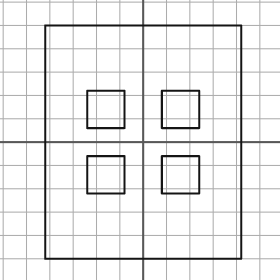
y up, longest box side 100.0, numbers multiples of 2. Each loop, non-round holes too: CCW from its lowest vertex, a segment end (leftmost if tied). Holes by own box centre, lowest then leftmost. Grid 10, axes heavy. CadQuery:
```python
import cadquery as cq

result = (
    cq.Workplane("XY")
    .moveTo(-42.0, -50.0)
    .lineTo(42.0, -50.0)
    .lineTo(42.0, 50.0)
    .lineTo(-42.0, 50.0)
    .close()
    .moveTo(-24.0, -22.0)
    .lineTo(-8.0, -22.0)
    .lineTo(-8.0, -6.0)
    .lineTo(-24.0, -6.0)
    .close()
    .moveTo(8.0, -22.0)
    .lineTo(24.0, -22.0)
    .lineTo(24.0, -6.0)
    .lineTo(8.0, -6.0)
    .close()
    .moveTo(-24.0, 6.0)
    .lineTo(-8.0, 6.0)
    .lineTo(-8.0, 22.0)
    .lineTo(-24.0, 22.0)
    .close()
    .moveTo(8.0, 6.0)
    .lineTo(24.0, 6.0)
    .lineTo(24.0, 22.0)
    .lineTo(8.0, 22.0)
    .close()
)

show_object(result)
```